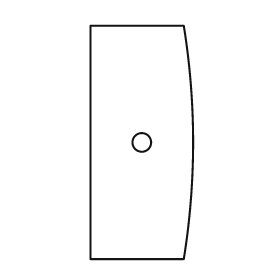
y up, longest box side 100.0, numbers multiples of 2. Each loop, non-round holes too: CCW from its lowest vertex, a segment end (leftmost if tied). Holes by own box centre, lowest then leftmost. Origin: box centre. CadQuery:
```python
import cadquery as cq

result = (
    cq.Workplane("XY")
    .moveTo(-22.0, -50.0)
    .lineTo(18.0, -50.0)
    .threePointArc((22.0, 0.0), (18.0, 50.0))
    .lineTo(-22.0, 50.0)
    .close()
    .moveTo(0.0, 0.0)
    .circle(4.0)
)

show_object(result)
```